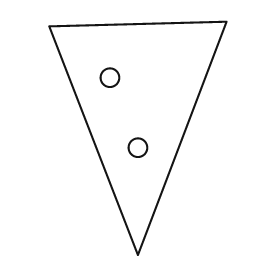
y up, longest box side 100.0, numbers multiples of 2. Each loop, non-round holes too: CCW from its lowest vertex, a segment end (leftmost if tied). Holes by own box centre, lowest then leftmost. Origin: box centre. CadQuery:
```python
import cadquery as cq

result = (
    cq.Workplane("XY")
    .moveTo(0.0, -50.0)
    .lineTo(38.0, 50.0)
    .lineTo(-38.0, 48.0)
    .close()
    .moveTo(0.0, -4.0)
    .circle(4.0)
    .moveTo(-12.0, 26.0)
    .circle(4.0)
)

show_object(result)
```